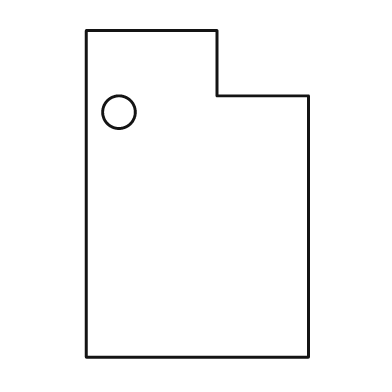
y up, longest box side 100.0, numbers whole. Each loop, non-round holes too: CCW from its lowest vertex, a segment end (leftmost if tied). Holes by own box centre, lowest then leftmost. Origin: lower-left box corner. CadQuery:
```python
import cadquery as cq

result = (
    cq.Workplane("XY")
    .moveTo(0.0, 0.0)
    .lineTo(68.0, 0.0)
    .lineTo(68.0, 80.0)
    .lineTo(40.0, 80.0)
    .lineTo(40.0, 100.0)
    .lineTo(0.0, 100.0)
    .close()
    .moveTo(10.0, 75.0)
    .circle(5.0)
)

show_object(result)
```